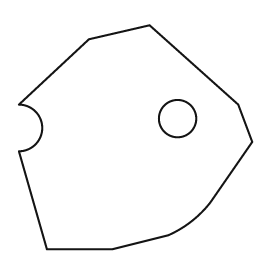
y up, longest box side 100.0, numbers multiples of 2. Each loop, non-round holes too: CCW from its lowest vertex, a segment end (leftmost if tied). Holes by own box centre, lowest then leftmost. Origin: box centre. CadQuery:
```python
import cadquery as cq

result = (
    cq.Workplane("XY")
    .moveTo(-38.0, -48.0)
    .lineTo(-10.0, -48.0)
    .lineTo(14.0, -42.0)
    .threePointArc((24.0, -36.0), (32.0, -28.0))
    .lineTo(50.0, -2.0)
    .lineTo(44.0, 14.0)
    .lineTo(6.0, 48.0)
    .lineTo(-20.0, 42.0)
    .lineTo(-50.0, 14.0)
    .threePointArc((-40.0, 4.0), (-50.0, -6.0))
    .close()
    .moveTo(18.0, 8.0)
    .circle(8.0)
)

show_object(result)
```